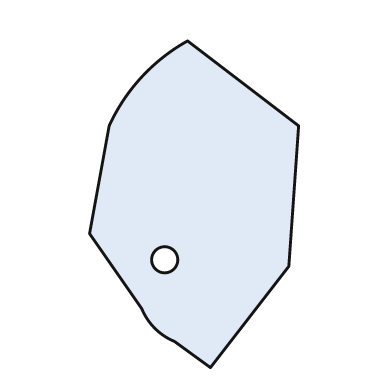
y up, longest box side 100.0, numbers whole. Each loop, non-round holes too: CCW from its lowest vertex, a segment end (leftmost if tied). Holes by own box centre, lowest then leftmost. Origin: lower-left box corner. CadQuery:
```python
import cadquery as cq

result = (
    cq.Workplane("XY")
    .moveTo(37.0, 0.0)
    .lineTo(61.0, 31.0)
    .lineTo(64.0, 74.0)
    .lineTo(30.0, 100.0)
    .threePointArc((16.0, 89.0), (6.0, 74.0))
    .lineTo(0.0, 41.0)
    .lineTo(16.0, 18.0)
    .threePointArc((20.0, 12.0), (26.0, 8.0))
    .close()
    .moveTo(23.0, 33.0)
    .circle(4.0)
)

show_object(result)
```